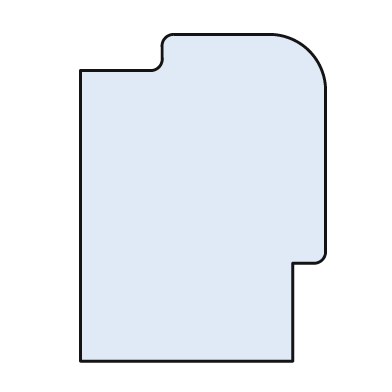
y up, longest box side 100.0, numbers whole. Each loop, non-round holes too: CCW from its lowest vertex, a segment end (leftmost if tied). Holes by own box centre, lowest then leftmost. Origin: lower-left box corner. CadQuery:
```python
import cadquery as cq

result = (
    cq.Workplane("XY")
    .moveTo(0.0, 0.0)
    .lineTo(65.0, 0.0)
    .lineTo(65.0, 30.0)
    .lineTo(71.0, 30.0)
    .threePointArc((74.0, 31.0), (75.0, 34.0))
    .lineTo(75.0, 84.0)
    .threePointArc((70.0, 95.0), (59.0, 100.0))
    .lineTo(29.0, 100.0)
    .threePointArc((26.0, 99.0), (25.0, 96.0))
    .lineTo(25.0, 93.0)
    .threePointArc((24.0, 90.0), (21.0, 89.0))
    .lineTo(0.0, 89.0)
    .close()
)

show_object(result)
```